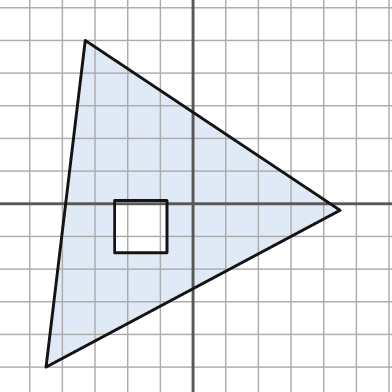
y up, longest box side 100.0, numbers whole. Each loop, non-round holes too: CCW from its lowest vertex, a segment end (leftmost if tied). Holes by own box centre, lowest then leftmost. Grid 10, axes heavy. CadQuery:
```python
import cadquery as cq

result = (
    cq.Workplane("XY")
    .moveTo(-45.0, -50.0)
    .lineTo(45.0, -2.0)
    .lineTo(-33.0, 50.0)
    .close()
    .moveTo(-24.0, -15.0)
    .lineTo(-8.0, -15.0)
    .lineTo(-8.0, 1.0)
    .lineTo(-24.0, 1.0)
    .close()
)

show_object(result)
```